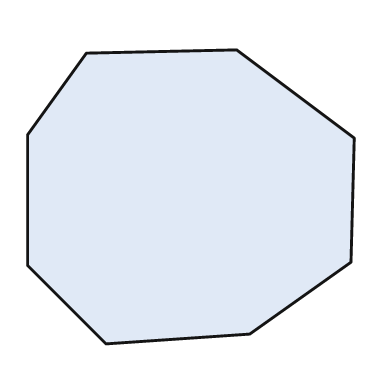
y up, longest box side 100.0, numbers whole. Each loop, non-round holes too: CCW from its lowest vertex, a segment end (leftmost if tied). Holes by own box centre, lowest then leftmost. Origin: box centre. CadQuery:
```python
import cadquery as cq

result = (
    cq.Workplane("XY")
    .moveTo(-26.0, -45.0)
    .lineTo(18.0, -42.0)
    .lineTo(49.0, -20.0)
    .lineTo(50.0, 18.0)
    .lineTo(14.0, 45.0)
    .lineTo(-32.0, 44.0)
    .lineTo(-50.0, 19.0)
    .lineTo(-50.0, -21.0)
    .close()
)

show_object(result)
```